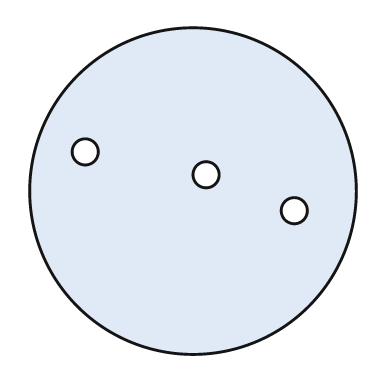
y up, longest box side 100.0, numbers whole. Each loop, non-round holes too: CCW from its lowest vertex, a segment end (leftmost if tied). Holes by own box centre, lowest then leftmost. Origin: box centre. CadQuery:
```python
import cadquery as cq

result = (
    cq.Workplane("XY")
    .moveTo(0.0, 0.0)
    .circle(50.0)
    .moveTo(31.0, -6.0)
    .circle(4.0)
    .moveTo(4.0, 5.0)
    .circle(4.0)
    .moveTo(-33.0, 12.0)
    .circle(4.0)
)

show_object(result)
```